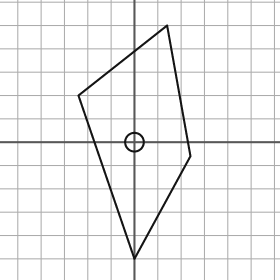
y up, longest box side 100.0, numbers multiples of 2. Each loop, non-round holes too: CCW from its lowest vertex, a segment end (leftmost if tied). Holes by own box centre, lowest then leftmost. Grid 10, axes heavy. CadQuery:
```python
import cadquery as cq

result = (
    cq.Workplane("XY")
    .moveTo(0.0, -50.0)
    .lineTo(24.0, -6.0)
    .lineTo(14.0, 50.0)
    .lineTo(-24.0, 20.0)
    .close()
    .moveTo(0.0, 0.0)
    .circle(4.0)
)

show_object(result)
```